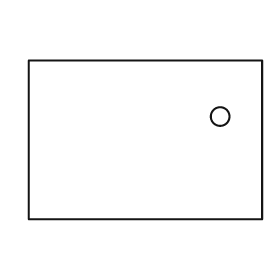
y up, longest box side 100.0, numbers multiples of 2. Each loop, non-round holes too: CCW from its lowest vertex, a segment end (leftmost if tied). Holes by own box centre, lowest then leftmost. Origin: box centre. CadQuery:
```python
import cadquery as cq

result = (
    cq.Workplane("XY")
    .moveTo(-50.0, -34.0)
    .lineTo(50.0, -34.0)
    .lineTo(50.0, 34.0)
    .lineTo(-50.0, 34.0)
    .close()
    .moveTo(32.0, 10.0)
    .circle(4.0)
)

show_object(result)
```